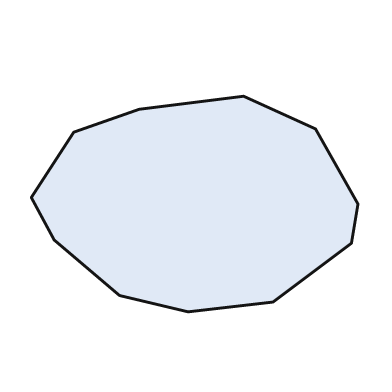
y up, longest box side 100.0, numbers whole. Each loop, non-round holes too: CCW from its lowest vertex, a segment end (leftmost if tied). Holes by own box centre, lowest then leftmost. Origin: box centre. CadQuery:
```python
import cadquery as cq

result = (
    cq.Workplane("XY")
    .moveTo(-2.0, -33.0)
    .lineTo(24.0, -30.0)
    .lineTo(48.0, -12.0)
    .lineTo(50.0, 0.0)
    .lineTo(37.0, 23.0)
    .lineTo(15.0, 33.0)
    .lineTo(-17.0, 29.0)
    .lineTo(-37.0, 22.0)
    .lineTo(-50.0, 2.0)
    .lineTo(-43.0, -11.0)
    .lineTo(-23.0, -28.0)
    .close()
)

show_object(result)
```